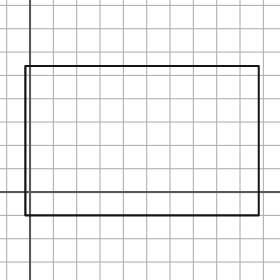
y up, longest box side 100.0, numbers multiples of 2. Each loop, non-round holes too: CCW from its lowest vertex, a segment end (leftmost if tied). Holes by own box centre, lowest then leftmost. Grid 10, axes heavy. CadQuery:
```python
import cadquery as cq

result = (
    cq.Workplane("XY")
    .moveTo(-2.0, -10.0)
    .lineTo(98.0, -10.0)
    .lineTo(98.0, 54.0)
    .lineTo(-2.0, 54.0)
    .close()
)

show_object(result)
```